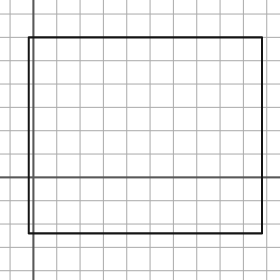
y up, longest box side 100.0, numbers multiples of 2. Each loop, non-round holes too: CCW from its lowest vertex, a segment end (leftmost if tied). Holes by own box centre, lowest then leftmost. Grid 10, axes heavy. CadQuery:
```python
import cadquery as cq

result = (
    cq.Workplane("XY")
    .moveTo(-2.0, -24.0)
    .lineTo(98.0, -24.0)
    .lineTo(98.0, 60.0)
    .lineTo(-2.0, 60.0)
    .close()
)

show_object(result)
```